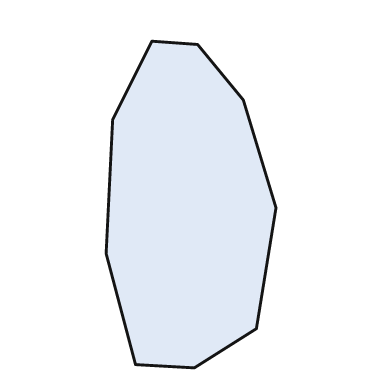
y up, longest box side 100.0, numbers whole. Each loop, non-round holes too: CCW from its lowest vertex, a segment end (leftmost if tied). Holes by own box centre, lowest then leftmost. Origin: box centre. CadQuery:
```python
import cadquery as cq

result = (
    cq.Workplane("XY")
    .moveTo(1.0, -50.0)
    .lineTo(20.0, -38.0)
    .lineTo(26.0, -1.0)
    .lineTo(16.0, 32.0)
    .lineTo(2.0, 49.0)
    .lineTo(-12.0, 50.0)
    .lineTo(-24.0, 26.0)
    .lineTo(-26.0, -15.0)
    .lineTo(-17.0, -49.0)
    .close()
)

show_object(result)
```